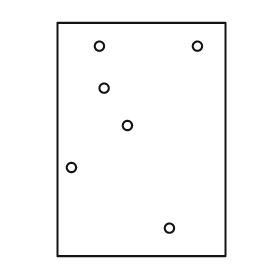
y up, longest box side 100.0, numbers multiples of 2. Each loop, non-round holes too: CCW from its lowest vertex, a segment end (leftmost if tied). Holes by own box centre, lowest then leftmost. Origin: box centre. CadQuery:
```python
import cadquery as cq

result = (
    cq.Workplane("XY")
    .moveTo(-36.0, -50.0)
    .lineTo(36.0, -50.0)
    .lineTo(36.0, 50.0)
    .lineTo(-36.0, 50.0)
    .close()
    .moveTo(12.0, -38.0)
    .circle(2.0)
    .moveTo(-30.0, -12.0)
    .circle(2.0)
    .moveTo(-6.0, 6.0)
    .circle(2.0)
    .moveTo(-16.0, 22.0)
    .circle(2.0)
    .moveTo(-18.0, 40.0)
    .circle(2.0)
    .moveTo(24.0, 40.0)
    .circle(2.0)
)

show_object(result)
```